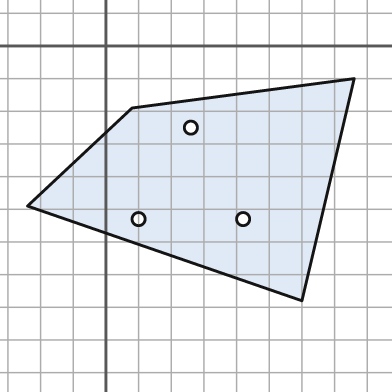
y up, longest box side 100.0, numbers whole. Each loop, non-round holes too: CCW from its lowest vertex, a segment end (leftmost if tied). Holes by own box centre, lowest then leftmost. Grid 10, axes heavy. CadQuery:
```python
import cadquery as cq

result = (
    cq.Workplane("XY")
    .moveTo(60.0, -78.0)
    .lineTo(76.0, -10.0)
    .lineTo(8.0, -19.0)
    .lineTo(-24.0, -49.0)
    .close()
    .moveTo(10.0, -53.0)
    .circle(2.0)
    .moveTo(42.0, -53.0)
    .circle(2.0)
    .moveTo(26.0, -25.0)
    .circle(2.0)
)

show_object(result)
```